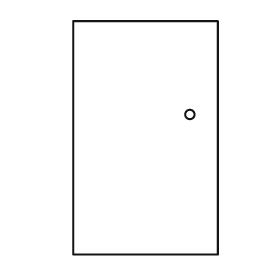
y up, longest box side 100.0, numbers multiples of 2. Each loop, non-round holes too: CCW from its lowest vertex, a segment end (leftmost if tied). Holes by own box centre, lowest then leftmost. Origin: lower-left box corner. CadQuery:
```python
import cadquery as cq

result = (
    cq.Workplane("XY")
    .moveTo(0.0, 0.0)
    .lineTo(62.0, 0.0)
    .lineTo(62.0, 100.0)
    .lineTo(0.0, 100.0)
    .close()
    .moveTo(50.0, 60.0)
    .circle(2.0)
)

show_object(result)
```